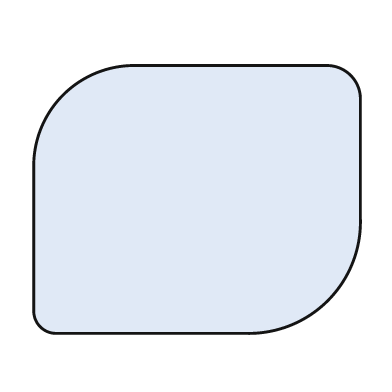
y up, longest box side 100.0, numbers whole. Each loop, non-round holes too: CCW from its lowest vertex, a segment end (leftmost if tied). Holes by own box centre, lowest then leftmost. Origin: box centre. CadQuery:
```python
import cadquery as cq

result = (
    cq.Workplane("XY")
    .moveTo(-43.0, -41.0)
    .lineTo(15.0, -41.0)
    .threePointArc((40.0, -31.0), (50.0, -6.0))
    .lineTo(50.0, 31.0)
    .threePointArc((47.0, 38.0), (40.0, 41.0))
    .lineTo(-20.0, 41.0)
    .threePointArc((-41.0, 32.0), (-50.0, 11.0))
    .lineTo(-50.0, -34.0)
    .threePointArc((-48.0, -39.0), (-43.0, -41.0))
    .close()
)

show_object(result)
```